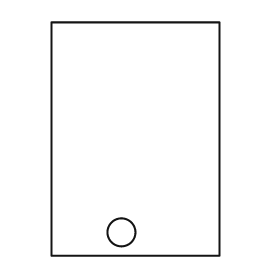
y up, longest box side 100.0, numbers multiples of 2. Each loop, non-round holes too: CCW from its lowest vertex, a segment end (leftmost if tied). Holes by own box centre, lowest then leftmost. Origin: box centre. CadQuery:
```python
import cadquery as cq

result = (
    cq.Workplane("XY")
    .moveTo(-36.0, -50.0)
    .lineTo(36.0, -50.0)
    .lineTo(36.0, 50.0)
    .lineTo(-36.0, 50.0)
    .close()
    .moveTo(-6.0, -40.0)
    .circle(6.0)
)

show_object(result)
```